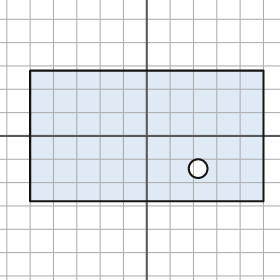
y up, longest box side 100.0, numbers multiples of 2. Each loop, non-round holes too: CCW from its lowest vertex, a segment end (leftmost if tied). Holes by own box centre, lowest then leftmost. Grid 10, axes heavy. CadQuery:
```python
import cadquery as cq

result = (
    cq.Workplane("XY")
    .moveTo(-50.0, -28.0)
    .lineTo(50.0, -28.0)
    .lineTo(50.0, 28.0)
    .lineTo(-50.0, 28.0)
    .close()
    .moveTo(22.0, -14.0)
    .circle(4.0)
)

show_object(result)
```